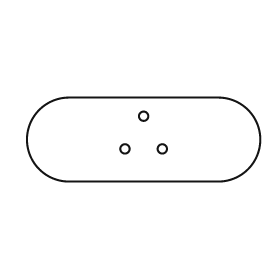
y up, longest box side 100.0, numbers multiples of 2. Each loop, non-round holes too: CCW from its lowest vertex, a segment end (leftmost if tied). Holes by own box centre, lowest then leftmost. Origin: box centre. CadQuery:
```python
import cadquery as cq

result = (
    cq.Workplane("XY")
    .moveTo(-32.0, -18.0)
    .lineTo(32.0, -18.0)
    .threePointArc((50.0, 0.0), (32.0, 18.0))
    .lineTo(-32.0, 18.0)
    .threePointArc((-50.0, 0.0), (-32.0, -18.0))
    .close()
    .moveTo(-8.0, -4.0)
    .circle(2.0)
    .moveTo(8.0, -4.0)
    .circle(2.0)
    .moveTo(0.0, 10.0)
    .circle(2.0)
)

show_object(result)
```